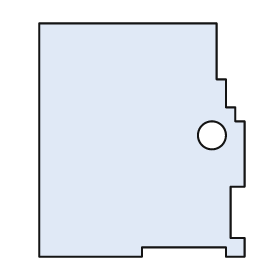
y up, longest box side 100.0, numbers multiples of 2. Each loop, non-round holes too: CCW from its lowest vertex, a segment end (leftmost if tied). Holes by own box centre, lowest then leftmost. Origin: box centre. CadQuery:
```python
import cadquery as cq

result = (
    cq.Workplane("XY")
    .moveTo(-44.0, -50.0)
    .lineTo(0.0, -50.0)
    .lineTo(0.0, -46.0)
    .lineTo(36.0, -46.0)
    .lineTo(36.0, -50.0)
    .lineTo(44.0, -50.0)
    .lineTo(44.0, -42.0)
    .lineTo(38.0, -42.0)
    .lineTo(38.0, -20.0)
    .lineTo(44.0, -20.0)
    .lineTo(44.0, 8.0)
    .lineTo(40.0, 8.0)
    .lineTo(40.0, 14.0)
    .lineTo(36.0, 14.0)
    .lineTo(36.0, 26.0)
    .lineTo(32.0, 26.0)
    .lineTo(32.0, 50.0)
    .lineTo(-44.0, 50.0)
    .close()
    .moveTo(30.0, 2.0)
    .circle(6.0)
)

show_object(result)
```